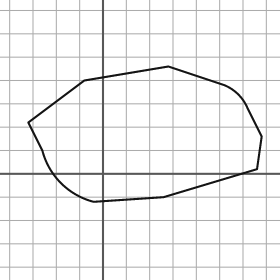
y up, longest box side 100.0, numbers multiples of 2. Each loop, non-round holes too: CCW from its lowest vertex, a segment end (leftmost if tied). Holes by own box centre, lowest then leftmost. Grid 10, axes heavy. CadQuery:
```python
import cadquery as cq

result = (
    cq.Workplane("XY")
    .moveTo(-4.0, -12.0)
    .lineTo(26.0, -10.0)
    .lineTo(66.0, 2.0)
    .lineTo(68.0, 16.0)
    .lineTo(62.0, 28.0)
    .threePointArc((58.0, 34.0), (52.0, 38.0))
    .lineTo(28.0, 46.0)
    .lineTo(-8.0, 40.0)
    .lineTo(-32.0, 22.0)
    .lineTo(-26.0, 10.0)
    .threePointArc((-18.0, -4.0), (-4.0, -12.0))
    .close()
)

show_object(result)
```